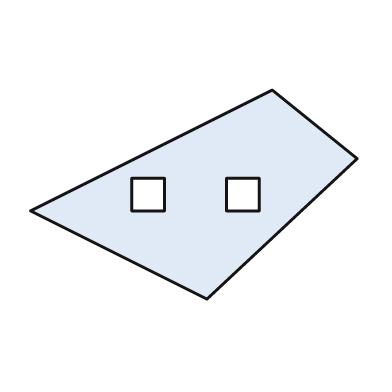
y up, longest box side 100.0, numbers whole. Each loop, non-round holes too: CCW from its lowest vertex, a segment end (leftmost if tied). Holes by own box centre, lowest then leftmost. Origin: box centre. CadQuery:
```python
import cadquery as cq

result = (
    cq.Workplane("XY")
    .moveTo(4.0, -32.0)
    .lineTo(50.0, 11.0)
    .lineTo(24.0, 32.0)
    .lineTo(-50.0, -5.0)
    .close()
    .moveTo(-19.0, -5.0)
    .lineTo(-9.0, -5.0)
    .lineTo(-9.0, 5.0)
    .lineTo(-19.0, 5.0)
    .close()
    .moveTo(10.0, -5.0)
    .lineTo(20.0, -5.0)
    .lineTo(20.0, 5.0)
    .lineTo(10.0, 5.0)
    .close()
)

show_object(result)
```